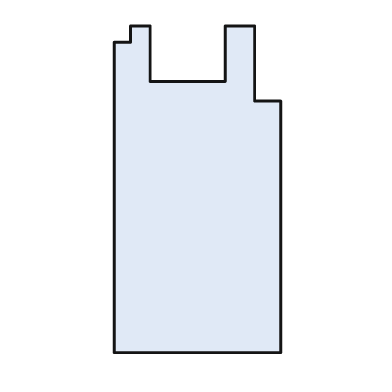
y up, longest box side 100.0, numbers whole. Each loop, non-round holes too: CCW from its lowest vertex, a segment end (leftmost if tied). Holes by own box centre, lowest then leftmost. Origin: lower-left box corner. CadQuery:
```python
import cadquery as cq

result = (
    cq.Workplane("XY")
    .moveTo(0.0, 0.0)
    .lineTo(51.0, 0.0)
    .lineTo(51.0, 77.0)
    .lineTo(43.0, 77.0)
    .lineTo(43.0, 100.0)
    .lineTo(34.0, 100.0)
    .lineTo(34.0, 83.0)
    .lineTo(11.0, 83.0)
    .lineTo(11.0, 100.0)
    .lineTo(5.0, 100.0)
    .lineTo(5.0, 95.0)
    .lineTo(0.0, 95.0)
    .close()
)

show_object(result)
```